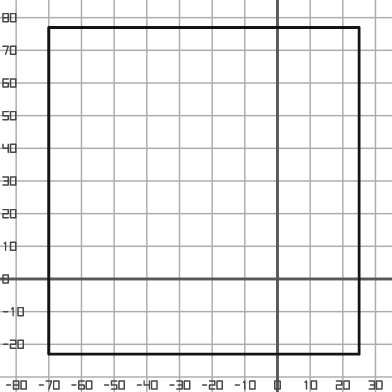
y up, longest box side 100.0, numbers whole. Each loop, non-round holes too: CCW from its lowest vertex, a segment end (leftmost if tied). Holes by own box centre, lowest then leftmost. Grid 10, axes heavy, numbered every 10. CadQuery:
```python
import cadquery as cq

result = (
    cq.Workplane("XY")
    .moveTo(-70.0, -23.0)
    .lineTo(25.0, -23.0)
    .lineTo(25.0, 77.0)
    .lineTo(-70.0, 77.0)
    .close()
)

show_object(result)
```